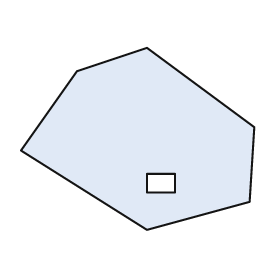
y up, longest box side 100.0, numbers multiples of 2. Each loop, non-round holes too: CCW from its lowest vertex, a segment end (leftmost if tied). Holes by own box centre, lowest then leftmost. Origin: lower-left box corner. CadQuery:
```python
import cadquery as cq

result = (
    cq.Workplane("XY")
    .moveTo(54.0, 0.0)
    .lineTo(98.0, 12.0)
    .lineTo(100.0, 44.0)
    .lineTo(54.0, 78.0)
    .lineTo(24.0, 68.0)
    .lineTo(0.0, 34.0)
    .close()
    .moveTo(54.0, 16.0)
    .lineTo(66.0, 16.0)
    .lineTo(66.0, 24.0)
    .lineTo(54.0, 24.0)
    .close()
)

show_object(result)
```